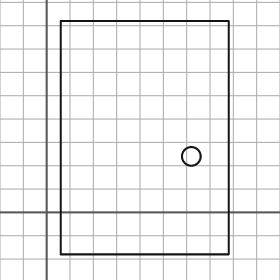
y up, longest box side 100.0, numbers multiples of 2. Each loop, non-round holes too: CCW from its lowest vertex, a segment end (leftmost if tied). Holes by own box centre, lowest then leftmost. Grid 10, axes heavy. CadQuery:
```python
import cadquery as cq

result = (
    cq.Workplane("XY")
    .moveTo(6.0, -18.0)
    .lineTo(78.0, -18.0)
    .lineTo(78.0, 82.0)
    .lineTo(6.0, 82.0)
    .close()
    .moveTo(62.0, 24.0)
    .circle(4.0)
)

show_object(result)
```